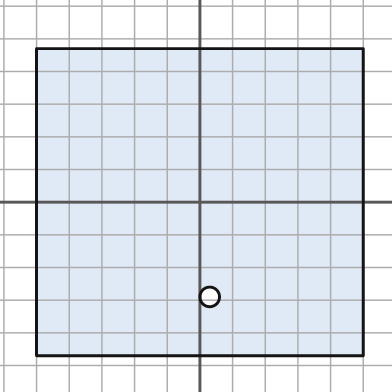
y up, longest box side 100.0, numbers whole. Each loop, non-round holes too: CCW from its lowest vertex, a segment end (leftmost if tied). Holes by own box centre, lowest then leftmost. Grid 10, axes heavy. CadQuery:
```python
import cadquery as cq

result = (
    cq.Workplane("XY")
    .moveTo(-50.0, -47.0)
    .lineTo(50.0, -47.0)
    .lineTo(50.0, 47.0)
    .lineTo(-50.0, 47.0)
    .close()
    .moveTo(3.0, -29.0)
    .circle(3.0)
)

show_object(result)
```